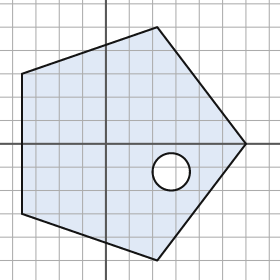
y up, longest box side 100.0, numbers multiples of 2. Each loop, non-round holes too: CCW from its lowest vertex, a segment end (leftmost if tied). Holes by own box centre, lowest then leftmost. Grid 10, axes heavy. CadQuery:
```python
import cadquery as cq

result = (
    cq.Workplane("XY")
    .moveTo(22.0, -50.0)
    .lineTo(60.0, 0.0)
    .lineTo(22.0, 50.0)
    .lineTo(-36.0, 30.0)
    .lineTo(-36.0, -30.0)
    .close()
    .moveTo(28.0, -12.0)
    .circle(8.0)
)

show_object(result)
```